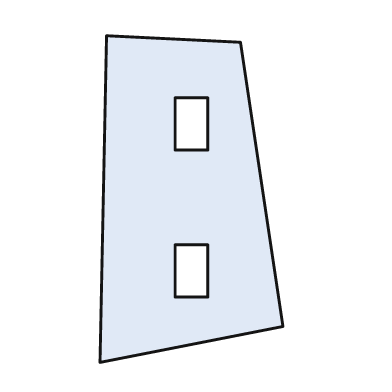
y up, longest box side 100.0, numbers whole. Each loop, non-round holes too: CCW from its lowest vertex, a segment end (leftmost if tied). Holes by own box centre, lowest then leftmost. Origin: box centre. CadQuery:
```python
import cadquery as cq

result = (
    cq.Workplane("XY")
    .moveTo(-28.0, -50.0)
    .lineTo(28.0, -39.0)
    .lineTo(15.0, 48.0)
    .lineTo(-26.0, 50.0)
    .close()
    .moveTo(-5.0, -30.0)
    .lineTo(5.0, -30.0)
    .lineTo(5.0, -14.0)
    .lineTo(-5.0, -14.0)
    .close()
    .moveTo(-5.0, 15.0)
    .lineTo(5.0, 15.0)
    .lineTo(5.0, 31.0)
    .lineTo(-5.0, 31.0)
    .close()
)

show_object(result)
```